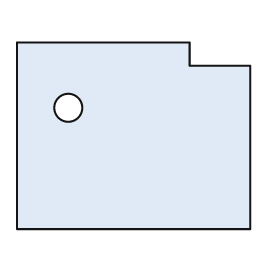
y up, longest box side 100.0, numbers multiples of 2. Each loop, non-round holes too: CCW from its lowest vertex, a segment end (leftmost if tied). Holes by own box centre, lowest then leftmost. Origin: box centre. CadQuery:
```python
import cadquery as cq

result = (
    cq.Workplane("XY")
    .moveTo(-50.0, -40.0)
    .lineTo(50.0, -40.0)
    .lineTo(50.0, 30.0)
    .lineTo(24.0, 30.0)
    .lineTo(24.0, 40.0)
    .lineTo(-50.0, 40.0)
    .close()
    .moveTo(-28.0, 12.0)
    .circle(6.0)
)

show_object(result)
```